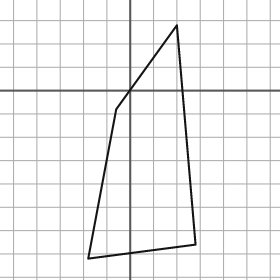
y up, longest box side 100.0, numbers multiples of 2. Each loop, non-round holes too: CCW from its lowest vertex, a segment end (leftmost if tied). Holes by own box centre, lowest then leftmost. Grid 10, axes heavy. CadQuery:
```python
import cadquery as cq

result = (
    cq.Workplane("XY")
    .moveTo(-18.0, -72.0)
    .lineTo(28.0, -66.0)
    .lineTo(20.0, 28.0)
    .lineTo(-6.0, -8.0)
    .close()
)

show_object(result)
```